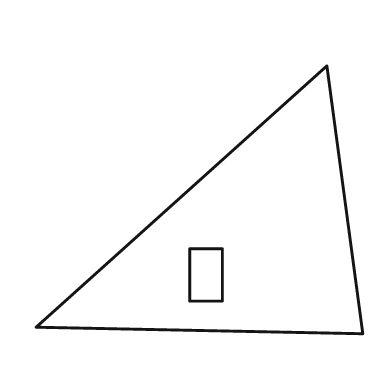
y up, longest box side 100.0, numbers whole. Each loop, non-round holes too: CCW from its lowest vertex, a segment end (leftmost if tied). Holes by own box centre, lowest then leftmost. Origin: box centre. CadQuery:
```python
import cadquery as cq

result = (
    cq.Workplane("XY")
    .moveTo(50.0, -41.0)
    .lineTo(39.0, 41.0)
    .lineTo(-50.0, -39.0)
    .close()
    .moveTo(-3.0, -31.0)
    .lineTo(7.0, -31.0)
    .lineTo(7.0, -15.0)
    .lineTo(-3.0, -15.0)
    .close()
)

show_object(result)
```